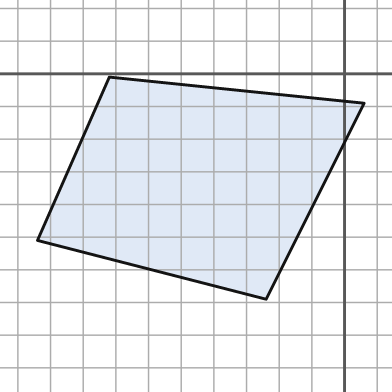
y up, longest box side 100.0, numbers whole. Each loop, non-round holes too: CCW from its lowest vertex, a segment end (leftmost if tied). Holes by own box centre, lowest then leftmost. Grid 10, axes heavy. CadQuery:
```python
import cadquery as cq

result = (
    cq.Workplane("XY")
    .moveTo(-24.0, -69.0)
    .lineTo(6.0, -9.0)
    .lineTo(-72.0, -1.0)
    .lineTo(-94.0, -51.0)
    .close()
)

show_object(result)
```